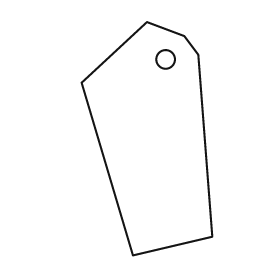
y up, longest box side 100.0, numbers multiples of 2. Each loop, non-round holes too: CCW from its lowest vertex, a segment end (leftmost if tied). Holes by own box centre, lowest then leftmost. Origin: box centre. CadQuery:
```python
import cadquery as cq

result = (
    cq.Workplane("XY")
    .moveTo(-6.0, -50.0)
    .lineTo(28.0, -42.0)
    .lineTo(22.0, 36.0)
    .lineTo(16.0, 44.0)
    .lineTo(0.0, 50.0)
    .lineTo(-28.0, 24.0)
    .close()
    .moveTo(8.0, 34.0)
    .circle(4.0)
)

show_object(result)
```